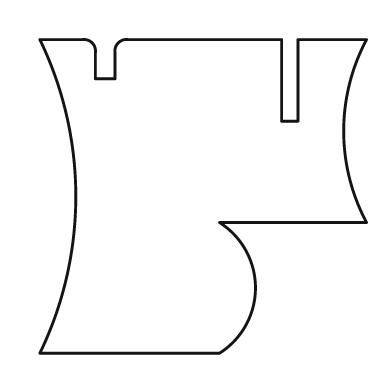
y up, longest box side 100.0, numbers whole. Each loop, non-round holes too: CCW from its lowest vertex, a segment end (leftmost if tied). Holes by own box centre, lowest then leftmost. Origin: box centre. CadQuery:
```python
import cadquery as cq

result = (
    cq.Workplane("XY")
    .moveTo(-50.0, -48.0)
    .lineTo(5.0, -48.0)
    .threePointArc((16.0, -28.0), (5.0, -8.0))
    .lineTo(50.0, -8.0)
    .threePointArc((43.0, 20.0), (50.0, 48.0))
    .lineTo(29.0, 48.0)
    .lineTo(29.0, 23.0)
    .lineTo(24.0, 23.0)
    .lineTo(24.0, 48.0)
    .lineTo(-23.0, 48.0)
    .threePointArc((-26.0, 47.0), (-27.0, 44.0))
    .lineTo(-27.0, 36.0)
    .lineTo(-33.0, 36.0)
    .lineTo(-33.0, 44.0)
    .threePointArc((-34.0, 47.0), (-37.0, 48.0))
    .lineTo(-50.0, 48.0)
    .threePointArc((-39.0, 0.0), (-50.0, -48.0))
    .close()
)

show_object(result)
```